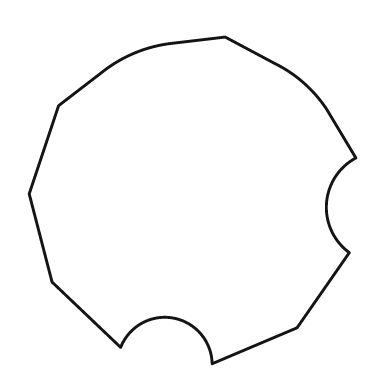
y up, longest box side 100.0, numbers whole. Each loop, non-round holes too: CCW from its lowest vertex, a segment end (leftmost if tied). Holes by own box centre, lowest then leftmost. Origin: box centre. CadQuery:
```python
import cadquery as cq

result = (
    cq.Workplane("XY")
    .moveTo(6.0, -50.0)
    .lineTo(32.0, -39.0)
    .lineTo(48.0, -16.0)
    .threePointArc((41.0, -1.0), (50.0, 13.0))
    .lineTo(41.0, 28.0)
    .threePointArc((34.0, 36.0), (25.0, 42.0))
    .lineTo(10.0, 50.0)
    .lineTo(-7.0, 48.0)
    .threePointArc((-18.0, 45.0), (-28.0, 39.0))
    .lineTo(-41.0, 29.0)
    .lineTo(-50.0, 2.0)
    .lineTo(-43.0, -25.0)
    .lineTo(-22.0, -45.0)
    .threePointArc((-6.0, -36.0), (6.0, -50.0))
    .close()
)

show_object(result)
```